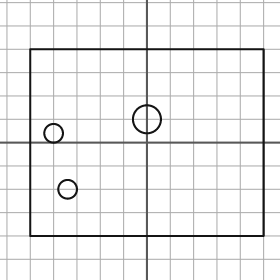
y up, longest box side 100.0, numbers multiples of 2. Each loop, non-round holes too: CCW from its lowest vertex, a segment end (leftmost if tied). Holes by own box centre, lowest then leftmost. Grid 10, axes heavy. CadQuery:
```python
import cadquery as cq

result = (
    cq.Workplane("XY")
    .moveTo(-50.0, -40.0)
    .lineTo(50.0, -40.0)
    .lineTo(50.0, 40.0)
    .lineTo(-50.0, 40.0)
    .close()
    .moveTo(-34.0, -20.0)
    .circle(4.0)
    .moveTo(-40.0, 4.0)
    .circle(4.0)
    .moveTo(0.0, 10.0)
    .circle(6.0)
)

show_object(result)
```